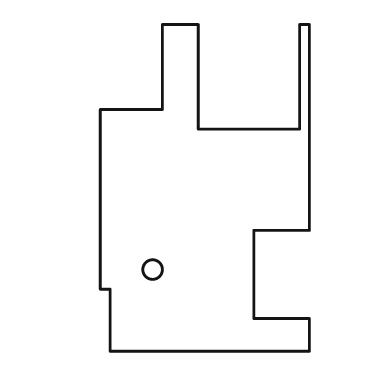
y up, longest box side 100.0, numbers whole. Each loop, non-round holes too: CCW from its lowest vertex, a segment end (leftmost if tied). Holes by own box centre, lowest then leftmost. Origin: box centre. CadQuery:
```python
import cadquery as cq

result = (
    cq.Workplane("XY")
    .moveTo(-29.0, -50.0)
    .lineTo(32.0, -50.0)
    .lineTo(32.0, -40.0)
    .lineTo(15.0, -40.0)
    .lineTo(15.0, -13.0)
    .lineTo(32.0, -13.0)
    .lineTo(32.0, 50.0)
    .lineTo(29.0, 50.0)
    .lineTo(29.0, 18.0)
    .lineTo(-2.0, 18.0)
    .lineTo(-2.0, 50.0)
    .lineTo(-13.0, 50.0)
    .lineTo(-13.0, 24.0)
    .lineTo(-32.0, 24.0)
    .lineTo(-32.0, -31.0)
    .lineTo(-29.0, -31.0)
    .close()
    .moveTo(-16.0, -25.0)
    .circle(3.0)
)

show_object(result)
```